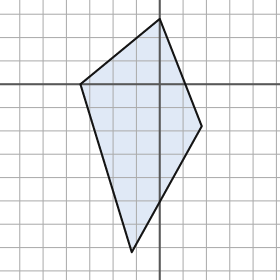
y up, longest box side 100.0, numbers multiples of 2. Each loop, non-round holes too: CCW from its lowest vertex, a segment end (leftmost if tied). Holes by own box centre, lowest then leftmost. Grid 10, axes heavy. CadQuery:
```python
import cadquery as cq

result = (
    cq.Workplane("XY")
    .moveTo(-12.0, -72.0)
    .lineTo(18.0, -18.0)
    .lineTo(0.0, 28.0)
    .lineTo(-34.0, 0.0)
    .close()
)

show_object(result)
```